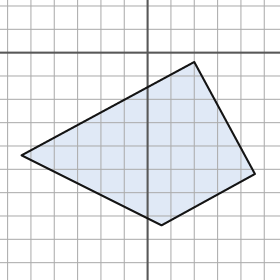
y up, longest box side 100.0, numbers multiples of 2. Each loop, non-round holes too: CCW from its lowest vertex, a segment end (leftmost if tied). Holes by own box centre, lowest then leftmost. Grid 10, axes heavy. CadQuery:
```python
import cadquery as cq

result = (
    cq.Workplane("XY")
    .moveTo(6.0, -74.0)
    .lineTo(46.0, -52.0)
    .lineTo(20.0, -4.0)
    .lineTo(-54.0, -44.0)
    .close()
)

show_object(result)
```